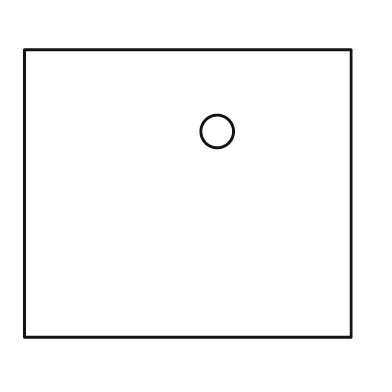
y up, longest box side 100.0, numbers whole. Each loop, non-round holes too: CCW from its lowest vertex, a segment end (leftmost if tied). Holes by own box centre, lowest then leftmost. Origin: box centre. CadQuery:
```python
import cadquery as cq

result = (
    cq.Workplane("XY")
    .moveTo(-50.0, -44.0)
    .lineTo(50.0, -44.0)
    .lineTo(50.0, 44.0)
    .lineTo(-50.0, 44.0)
    .close()
    .moveTo(9.0, 19.0)
    .circle(5.0)
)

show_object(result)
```